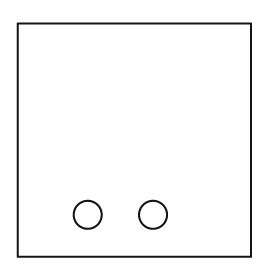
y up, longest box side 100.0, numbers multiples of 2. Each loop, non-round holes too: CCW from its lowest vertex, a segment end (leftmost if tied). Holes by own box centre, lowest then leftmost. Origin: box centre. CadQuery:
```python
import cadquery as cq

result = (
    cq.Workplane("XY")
    .moveTo(-50.0, -50.0)
    .lineTo(50.0, -50.0)
    .lineTo(50.0, 50.0)
    .lineTo(-50.0, 50.0)
    .close()
    .moveTo(-20.0, -32.0)
    .circle(6.0)
    .moveTo(8.0, -32.0)
    .circle(6.0)
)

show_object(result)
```